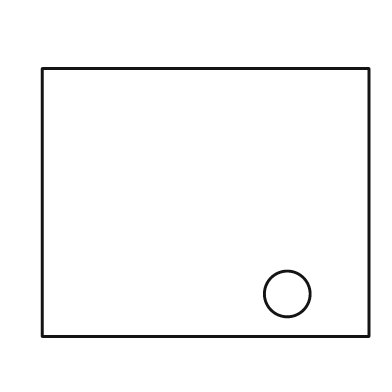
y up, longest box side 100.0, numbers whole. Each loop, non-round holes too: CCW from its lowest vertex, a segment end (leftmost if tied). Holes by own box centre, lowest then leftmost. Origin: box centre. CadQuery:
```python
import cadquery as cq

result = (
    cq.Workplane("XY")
    .moveTo(-50.0, -41.0)
    .lineTo(50.0, -41.0)
    .lineTo(50.0, 41.0)
    .lineTo(-50.0, 41.0)
    .close()
    .moveTo(25.0, -28.0)
    .circle(7.0)
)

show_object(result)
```